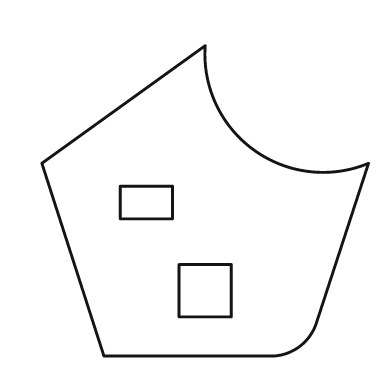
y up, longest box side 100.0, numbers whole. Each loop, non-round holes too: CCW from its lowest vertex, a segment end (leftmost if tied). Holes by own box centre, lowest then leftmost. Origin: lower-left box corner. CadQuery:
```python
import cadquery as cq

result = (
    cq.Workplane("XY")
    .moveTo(19.0, 0.0)
    .lineTo(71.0, 0.0)
    .threePointArc((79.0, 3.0), (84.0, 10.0))
    .lineTo(100.0, 59.0)
    .threePointArc((65.0, 63.0), (50.0, 95.0))
    .lineTo(0.0, 59.0)
    .close()
    .moveTo(42.0, 12.0)
    .lineTo(58.0, 12.0)
    .lineTo(58.0, 28.0)
    .lineTo(42.0, 28.0)
    .close()
    .moveTo(24.0, 42.0)
    .lineTo(40.0, 42.0)
    .lineTo(40.0, 52.0)
    .lineTo(24.0, 52.0)
    .close()
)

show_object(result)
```